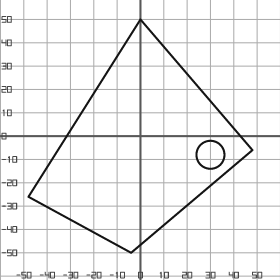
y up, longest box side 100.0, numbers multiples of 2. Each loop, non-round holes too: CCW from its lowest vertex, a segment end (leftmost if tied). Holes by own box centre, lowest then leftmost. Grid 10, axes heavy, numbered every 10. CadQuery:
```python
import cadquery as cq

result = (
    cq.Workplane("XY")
    .moveTo(-4.0, -50.0)
    .lineTo(48.0, -6.0)
    .lineTo(0.0, 50.0)
    .lineTo(-48.0, -26.0)
    .close()
    .moveTo(30.0, -8.0)
    .circle(6.0)
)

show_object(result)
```